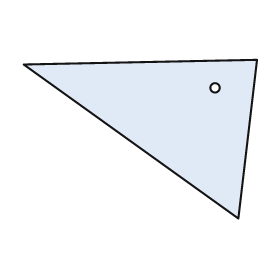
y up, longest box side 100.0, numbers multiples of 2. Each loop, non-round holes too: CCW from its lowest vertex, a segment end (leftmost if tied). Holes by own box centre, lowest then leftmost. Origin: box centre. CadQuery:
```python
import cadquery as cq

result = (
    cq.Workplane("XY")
    .moveTo(42.0, -34.0)
    .lineTo(50.0, 34.0)
    .lineTo(-50.0, 32.0)
    .close()
    .moveTo(32.0, 22.0)
    .circle(2.0)
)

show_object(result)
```